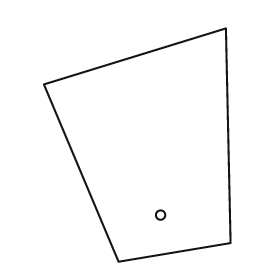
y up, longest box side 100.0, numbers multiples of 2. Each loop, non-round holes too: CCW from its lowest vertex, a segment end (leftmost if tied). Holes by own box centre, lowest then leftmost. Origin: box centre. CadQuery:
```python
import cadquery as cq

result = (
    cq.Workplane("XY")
    .moveTo(-8.0, -50.0)
    .lineTo(40.0, -42.0)
    .lineTo(38.0, 50.0)
    .lineTo(-40.0, 26.0)
    .close()
    .moveTo(10.0, -30.0)
    .circle(2.0)
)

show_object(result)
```